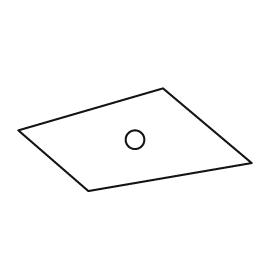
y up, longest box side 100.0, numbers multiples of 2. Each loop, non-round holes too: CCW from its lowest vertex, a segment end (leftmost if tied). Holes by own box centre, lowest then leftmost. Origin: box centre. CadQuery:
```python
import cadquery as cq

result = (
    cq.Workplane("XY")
    .moveTo(-20.0, -22.0)
    .lineTo(50.0, -10.0)
    .lineTo(12.0, 22.0)
    .lineTo(-50.0, 4.0)
    .close()
    .moveTo(0.0, 0.0)
    .circle(4.0)
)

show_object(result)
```